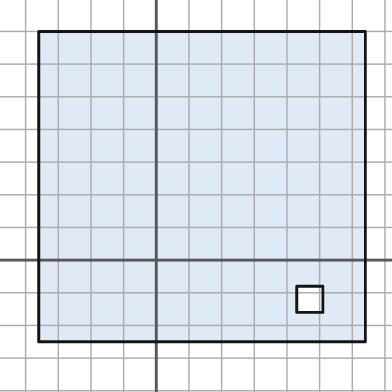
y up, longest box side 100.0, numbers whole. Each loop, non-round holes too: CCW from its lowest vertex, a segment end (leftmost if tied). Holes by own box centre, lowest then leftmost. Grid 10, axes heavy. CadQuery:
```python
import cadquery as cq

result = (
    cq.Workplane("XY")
    .moveTo(-36.0, -25.0)
    .lineTo(64.0, -25.0)
    .lineTo(64.0, 70.0)
    .lineTo(-36.0, 70.0)
    .close()
    .moveTo(43.0, -16.0)
    .lineTo(51.0, -16.0)
    .lineTo(51.0, -8.0)
    .lineTo(43.0, -8.0)
    .close()
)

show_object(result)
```